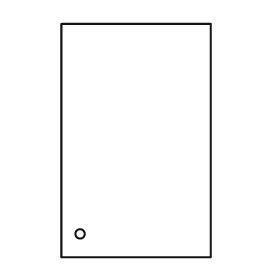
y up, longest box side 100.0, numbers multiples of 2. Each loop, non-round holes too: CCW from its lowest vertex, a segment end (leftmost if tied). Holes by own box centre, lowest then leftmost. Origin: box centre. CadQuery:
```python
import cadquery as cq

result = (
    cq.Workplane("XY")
    .moveTo(-32.0, -50.0)
    .lineTo(32.0, -50.0)
    .lineTo(32.0, 50.0)
    .lineTo(-32.0, 50.0)
    .close()
    .moveTo(-24.0, -40.0)
    .circle(2.0)
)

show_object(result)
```